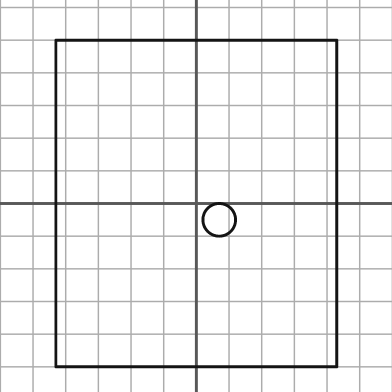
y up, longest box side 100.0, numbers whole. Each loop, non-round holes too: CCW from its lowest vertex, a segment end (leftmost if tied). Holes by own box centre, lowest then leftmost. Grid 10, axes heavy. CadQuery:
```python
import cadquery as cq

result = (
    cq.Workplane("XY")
    .moveTo(-43.0, -50.0)
    .lineTo(43.0, -50.0)
    .lineTo(43.0, 50.0)
    .lineTo(-43.0, 50.0)
    .close()
    .moveTo(7.0, -5.0)
    .circle(5.0)
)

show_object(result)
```